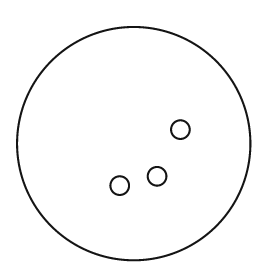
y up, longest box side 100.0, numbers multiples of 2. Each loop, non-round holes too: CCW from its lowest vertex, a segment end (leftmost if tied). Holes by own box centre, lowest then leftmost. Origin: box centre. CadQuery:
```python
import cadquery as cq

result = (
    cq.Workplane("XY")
    .moveTo(0.0, 0.0)
    .circle(50.0)
    .moveTo(-6.0, -18.0)
    .circle(4.0)
    .moveTo(10.0, -14.0)
    .circle(4.0)
    .moveTo(20.0, 6.0)
    .circle(4.0)
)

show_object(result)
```